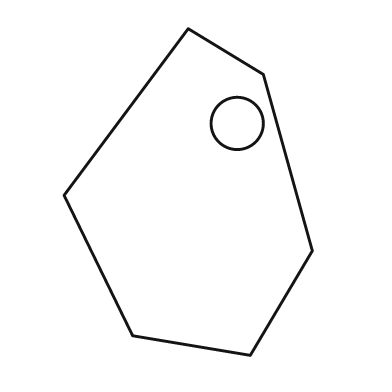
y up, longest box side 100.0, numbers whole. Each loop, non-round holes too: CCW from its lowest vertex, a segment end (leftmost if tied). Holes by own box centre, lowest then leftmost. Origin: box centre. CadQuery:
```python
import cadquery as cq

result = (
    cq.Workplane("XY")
    .moveTo(19.0, -50.0)
    .lineTo(38.0, -18.0)
    .lineTo(23.0, 36.0)
    .lineTo(0.0, 50.0)
    .lineTo(-38.0, -1.0)
    .lineTo(-17.0, -44.0)
    .close()
    .moveTo(15.0, 21.0)
    .circle(8.0)
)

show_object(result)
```